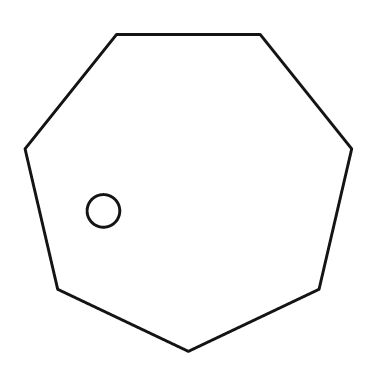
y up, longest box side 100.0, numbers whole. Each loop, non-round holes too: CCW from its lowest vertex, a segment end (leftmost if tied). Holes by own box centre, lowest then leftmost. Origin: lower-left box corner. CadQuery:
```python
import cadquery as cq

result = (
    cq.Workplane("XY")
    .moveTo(50.0, 0.0)
    .lineTo(90.0, 19.0)
    .lineTo(100.0, 62.0)
    .lineTo(72.0, 97.0)
    .lineTo(28.0, 97.0)
    .lineTo(0.0, 62.0)
    .lineTo(10.0, 19.0)
    .close()
    .moveTo(24.0, 43.0)
    .circle(5.0)
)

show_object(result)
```